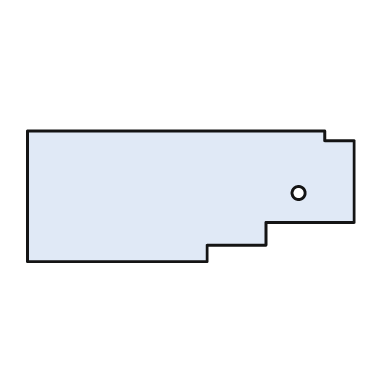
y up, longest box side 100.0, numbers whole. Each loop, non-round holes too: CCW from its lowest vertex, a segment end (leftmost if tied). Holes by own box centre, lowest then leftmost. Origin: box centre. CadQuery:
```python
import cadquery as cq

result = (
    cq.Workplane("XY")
    .moveTo(-50.0, -20.0)
    .lineTo(5.0, -20.0)
    .lineTo(5.0, -15.0)
    .lineTo(23.0, -15.0)
    .lineTo(23.0, -8.0)
    .lineTo(50.0, -8.0)
    .lineTo(50.0, 17.0)
    .lineTo(41.0, 17.0)
    .lineTo(41.0, 20.0)
    .lineTo(-50.0, 20.0)
    .close()
    .moveTo(33.0, 1.0)
    .circle(2.0)
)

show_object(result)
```